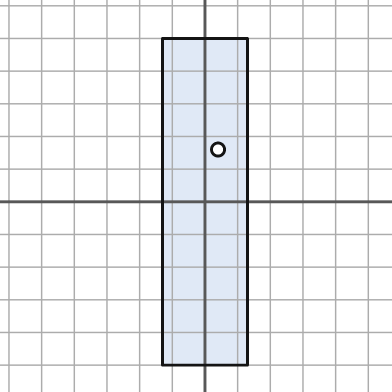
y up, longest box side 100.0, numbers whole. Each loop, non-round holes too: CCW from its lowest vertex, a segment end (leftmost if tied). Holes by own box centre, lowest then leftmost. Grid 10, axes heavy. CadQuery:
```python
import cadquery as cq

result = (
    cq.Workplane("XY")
    .moveTo(-13.0, -50.0)
    .lineTo(13.0, -50.0)
    .lineTo(13.0, 50.0)
    .lineTo(-13.0, 50.0)
    .close()
    .moveTo(4.0, 16.0)
    .circle(2.0)
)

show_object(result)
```